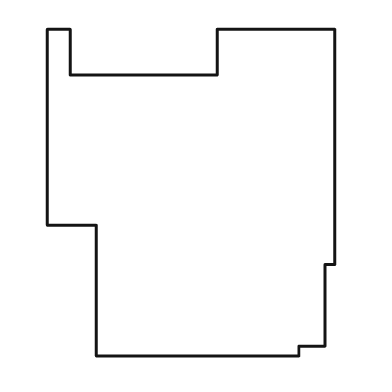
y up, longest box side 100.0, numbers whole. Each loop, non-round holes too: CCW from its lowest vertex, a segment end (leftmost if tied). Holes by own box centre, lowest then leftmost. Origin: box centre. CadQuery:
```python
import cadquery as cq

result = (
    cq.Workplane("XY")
    .moveTo(-29.0, -50.0)
    .lineTo(33.0, -50.0)
    .lineTo(33.0, -47.0)
    .lineTo(41.0, -47.0)
    .lineTo(41.0, -22.0)
    .lineTo(44.0, -22.0)
    .lineTo(44.0, 50.0)
    .lineTo(8.0, 50.0)
    .lineTo(8.0, 36.0)
    .lineTo(-37.0, 36.0)
    .lineTo(-37.0, 50.0)
    .lineTo(-44.0, 50.0)
    .lineTo(-44.0, -10.0)
    .lineTo(-29.0, -10.0)
    .close()
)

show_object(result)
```